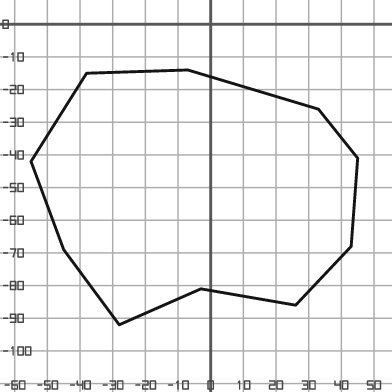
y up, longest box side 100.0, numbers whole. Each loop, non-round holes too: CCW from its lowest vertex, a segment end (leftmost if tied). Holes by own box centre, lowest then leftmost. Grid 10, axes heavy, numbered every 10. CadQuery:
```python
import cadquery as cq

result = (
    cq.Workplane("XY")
    .moveTo(-28.0, -92.0)
    .lineTo(-3.0, -81.0)
    .lineTo(26.0, -86.0)
    .lineTo(43.0, -68.0)
    .lineTo(45.0, -41.0)
    .lineTo(33.0, -26.0)
    .lineTo(-7.0, -14.0)
    .lineTo(-38.0, -15.0)
    .lineTo(-55.0, -42.0)
    .lineTo(-45.0, -69.0)
    .close()
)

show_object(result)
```